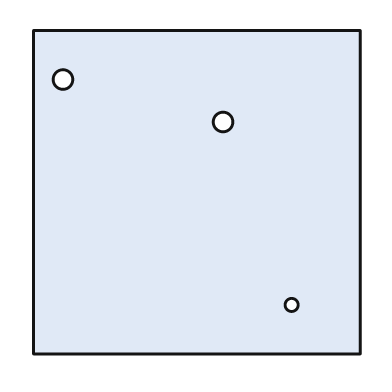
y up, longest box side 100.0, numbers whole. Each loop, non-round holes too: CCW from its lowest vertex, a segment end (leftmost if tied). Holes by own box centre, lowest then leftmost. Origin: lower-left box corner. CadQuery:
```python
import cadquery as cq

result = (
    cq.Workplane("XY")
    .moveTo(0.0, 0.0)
    .lineTo(100.0, 0.0)
    .lineTo(100.0, 99.0)
    .lineTo(0.0, 99.0)
    .close()
    .moveTo(79.0, 15.0)
    .circle(2.0)
    .moveTo(58.0, 71.0)
    .circle(3.0)
    .moveTo(9.0, 84.0)
    .circle(3.0)
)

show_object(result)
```